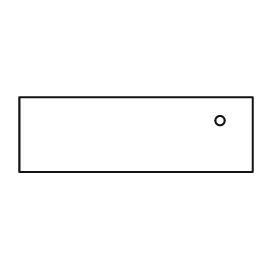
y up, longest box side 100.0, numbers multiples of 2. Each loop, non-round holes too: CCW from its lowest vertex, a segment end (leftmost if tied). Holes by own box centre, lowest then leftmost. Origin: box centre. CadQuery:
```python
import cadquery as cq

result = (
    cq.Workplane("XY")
    .moveTo(-50.0, -16.0)
    .lineTo(50.0, -16.0)
    .lineTo(50.0, 16.0)
    .lineTo(-50.0, 16.0)
    .close()
    .moveTo(36.0, 6.0)
    .circle(2.0)
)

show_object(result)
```